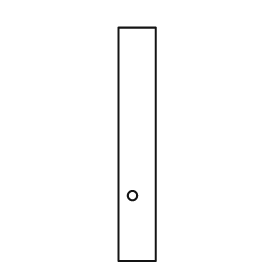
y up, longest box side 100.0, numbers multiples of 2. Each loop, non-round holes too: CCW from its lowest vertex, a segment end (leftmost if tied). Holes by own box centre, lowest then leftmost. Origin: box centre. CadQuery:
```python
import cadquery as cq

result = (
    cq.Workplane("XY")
    .moveTo(-8.0, -50.0)
    .lineTo(8.0, -50.0)
    .lineTo(8.0, 50.0)
    .lineTo(-8.0, 50.0)
    .close()
    .moveTo(-2.0, -22.0)
    .circle(2.0)
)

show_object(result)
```